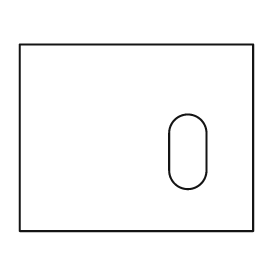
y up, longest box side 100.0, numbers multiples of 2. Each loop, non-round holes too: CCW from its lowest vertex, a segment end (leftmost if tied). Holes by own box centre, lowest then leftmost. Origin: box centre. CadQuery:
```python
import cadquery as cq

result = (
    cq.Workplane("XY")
    .moveTo(-50.0, -40.0)
    .lineTo(50.0, -40.0)
    .lineTo(50.0, 40.0)
    .lineTo(-50.0, 40.0)
    .close()
    .moveTo(14.0, -14.0)
    .threePointArc((22.0, -22.0), (30.0, -14.0))
    .lineTo(30.0, 2.0)
    .threePointArc((22.0, 10.0), (14.0, 2.0))
    .close()
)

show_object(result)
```